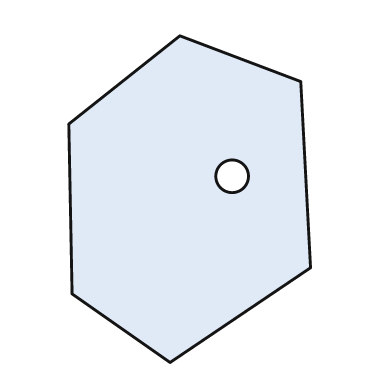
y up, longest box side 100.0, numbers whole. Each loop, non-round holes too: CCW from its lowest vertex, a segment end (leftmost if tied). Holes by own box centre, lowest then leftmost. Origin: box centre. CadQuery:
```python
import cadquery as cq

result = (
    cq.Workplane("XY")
    .moveTo(-6.0, -50.0)
    .lineTo(37.0, -21.0)
    .lineTo(34.0, 36.0)
    .lineTo(-3.0, 50.0)
    .lineTo(-37.0, 23.0)
    .lineTo(-36.0, -29.0)
    .close()
    .moveTo(13.0, 7.0)
    .circle(5.0)
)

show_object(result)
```